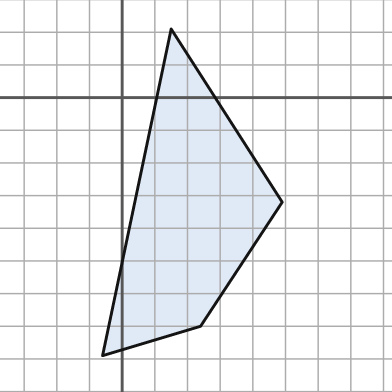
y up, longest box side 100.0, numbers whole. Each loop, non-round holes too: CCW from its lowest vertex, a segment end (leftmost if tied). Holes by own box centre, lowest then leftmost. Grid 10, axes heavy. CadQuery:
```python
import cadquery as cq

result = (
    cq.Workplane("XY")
    .moveTo(-6.0, -79.0)
    .lineTo(24.0, -70.0)
    .lineTo(49.0, -32.0)
    .lineTo(15.0, 21.0)
    .close()
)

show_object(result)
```